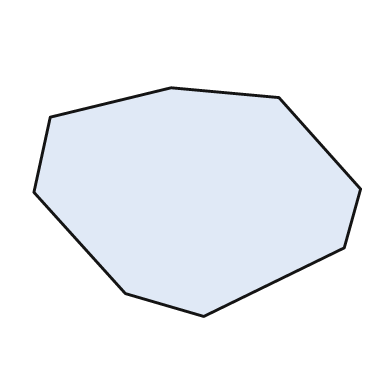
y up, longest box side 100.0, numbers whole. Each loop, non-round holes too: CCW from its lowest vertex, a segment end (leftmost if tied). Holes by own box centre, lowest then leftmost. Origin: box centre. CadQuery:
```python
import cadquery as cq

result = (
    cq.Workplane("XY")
    .moveTo(2.0, -35.0)
    .lineTo(45.0, -14.0)
    .lineTo(50.0, 4.0)
    .lineTo(25.0, 32.0)
    .lineTo(-8.0, 35.0)
    .lineTo(-45.0, 26.0)
    .lineTo(-50.0, 3.0)
    .lineTo(-22.0, -28.0)
    .close()
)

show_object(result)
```